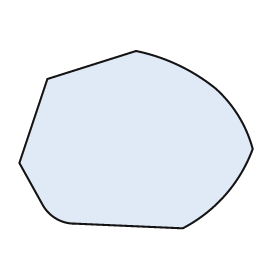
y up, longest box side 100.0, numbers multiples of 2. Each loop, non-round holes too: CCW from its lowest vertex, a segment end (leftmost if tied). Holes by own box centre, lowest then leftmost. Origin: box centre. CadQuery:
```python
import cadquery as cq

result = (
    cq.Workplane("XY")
    .moveTo(20.0, -38.0)
    .threePointArc((38.0, -24.0), (50.0, -4.0))
    .threePointArc((44.0, 10.0), (34.0, 22.0))
    .threePointArc((18.0, 32.0), (0.0, 38.0))
    .lineTo(-38.0, 26.0)
    .lineTo(-50.0, -10.0)
    .lineTo(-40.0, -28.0)
    .threePointArc((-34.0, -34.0), (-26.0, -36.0))
    .close()
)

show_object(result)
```